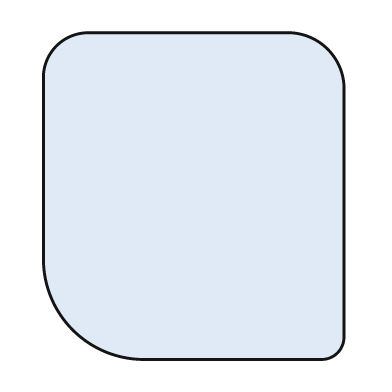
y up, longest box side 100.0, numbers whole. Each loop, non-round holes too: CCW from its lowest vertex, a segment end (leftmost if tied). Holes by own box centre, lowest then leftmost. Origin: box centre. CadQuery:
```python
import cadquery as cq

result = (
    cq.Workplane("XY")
    .moveTo(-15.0, -50.0)
    .lineTo(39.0, -50.0)
    .threePointArc((44.0, -48.0), (46.0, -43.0))
    .lineTo(46.0, 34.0)
    .threePointArc((41.0, 45.0), (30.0, 50.0))
    .lineTo(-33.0, 50.0)
    .threePointArc((-42.0, 46.0), (-46.0, 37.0))
    .lineTo(-46.0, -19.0)
    .threePointArc((-37.0, -41.0), (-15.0, -50.0))
    .close()
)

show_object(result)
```